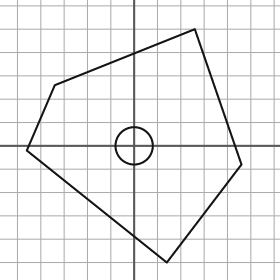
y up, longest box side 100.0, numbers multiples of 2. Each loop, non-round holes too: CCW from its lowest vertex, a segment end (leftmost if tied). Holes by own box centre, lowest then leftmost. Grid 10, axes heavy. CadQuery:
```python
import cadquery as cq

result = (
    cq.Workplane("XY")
    .moveTo(14.0, -50.0)
    .lineTo(46.0, -8.0)
    .lineTo(26.0, 50.0)
    .lineTo(-34.0, 26.0)
    .lineTo(-46.0, -2.0)
    .close()
    .moveTo(0.0, 0.0)
    .circle(8.0)
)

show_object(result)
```